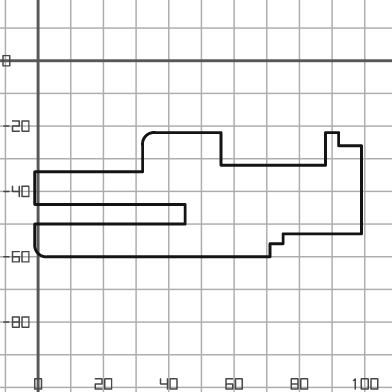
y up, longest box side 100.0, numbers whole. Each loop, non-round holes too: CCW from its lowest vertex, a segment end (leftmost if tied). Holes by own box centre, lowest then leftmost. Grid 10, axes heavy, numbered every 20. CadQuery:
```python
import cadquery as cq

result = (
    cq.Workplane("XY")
    .moveTo(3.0, -60.0)
    .lineTo(71.0, -60.0)
    .lineTo(71.0, -56.0)
    .lineTo(75.0, -56.0)
    .lineTo(75.0, -53.0)
    .lineTo(99.0, -53.0)
    .lineTo(99.0, -26.0)
    .lineTo(92.0, -26.0)
    .lineTo(92.0, -22.0)
    .lineTo(88.0, -22.0)
    .lineTo(88.0, -32.0)
    .lineTo(56.0, -32.0)
    .lineTo(56.0, -22.0)
    .lineTo(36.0, -22.0)
    .threePointArc((33.0, -23.0), (32.0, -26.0))
    .lineTo(32.0, -34.0)
    .lineTo(-1.0, -34.0)
    .lineTo(-1.0, -44.0)
    .lineTo(45.0, -44.0)
    .lineTo(45.0, -50.0)
    .lineTo(-1.0, -50.0)
    .lineTo(-1.0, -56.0)
    .threePointArc((0.0, -59.0), (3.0, -60.0))
    .close()
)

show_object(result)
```